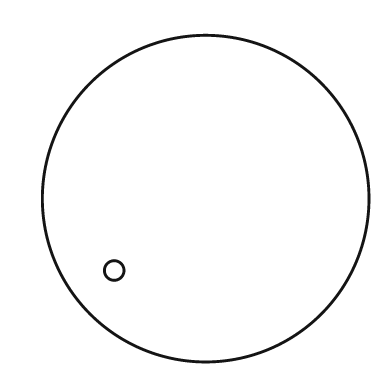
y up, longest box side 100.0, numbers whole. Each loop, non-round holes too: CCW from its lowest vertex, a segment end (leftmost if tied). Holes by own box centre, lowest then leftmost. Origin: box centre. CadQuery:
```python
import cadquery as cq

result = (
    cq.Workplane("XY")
    .moveTo(0.0, 0.0)
    .circle(50.0)
    .moveTo(-28.0, -22.0)
    .circle(3.0)
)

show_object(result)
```